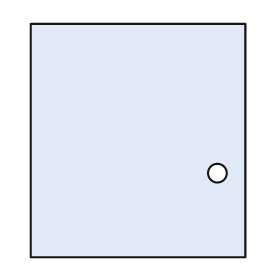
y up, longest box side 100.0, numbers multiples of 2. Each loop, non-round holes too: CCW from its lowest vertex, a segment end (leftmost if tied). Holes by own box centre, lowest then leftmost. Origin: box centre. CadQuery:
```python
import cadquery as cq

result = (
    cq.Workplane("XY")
    .moveTo(-46.0, -50.0)
    .lineTo(46.0, -50.0)
    .lineTo(46.0, 50.0)
    .lineTo(-46.0, 50.0)
    .close()
    .moveTo(34.0, -14.0)
    .circle(4.0)
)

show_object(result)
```